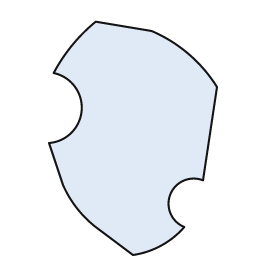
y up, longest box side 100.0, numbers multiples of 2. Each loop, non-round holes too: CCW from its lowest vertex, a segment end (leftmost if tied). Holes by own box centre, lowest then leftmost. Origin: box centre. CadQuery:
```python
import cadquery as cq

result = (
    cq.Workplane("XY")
    .moveTo(0.0, -50.0)
    .threePointArc((12.0, -46.0), (22.0, -38.0))
    .threePointArc((16.0, -24.0), (30.0, -18.0))
    .lineTo(36.0, 22.0)
    .threePointArc((24.0, 36.0), (8.0, 46.0))
    .lineTo(-16.0, 50.0)
    .threePointArc((-26.0, 40.0), (-34.0, 28.0))
    .threePointArc((-22.0, 12.0), (-36.0, -2.0))
    .lineTo(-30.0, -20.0)
    .threePointArc((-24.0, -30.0), (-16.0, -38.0))
    .close()
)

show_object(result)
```